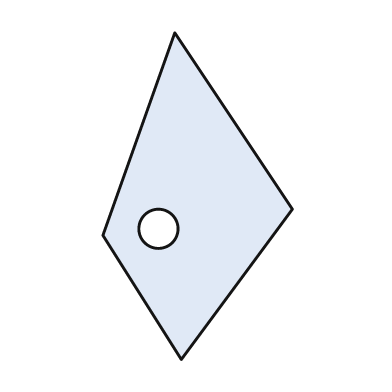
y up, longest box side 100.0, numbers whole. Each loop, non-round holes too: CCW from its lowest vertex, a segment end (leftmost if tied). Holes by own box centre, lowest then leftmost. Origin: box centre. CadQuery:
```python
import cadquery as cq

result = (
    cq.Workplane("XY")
    .moveTo(-5.0, -50.0)
    .lineTo(29.0, -4.0)
    .lineTo(-7.0, 50.0)
    .lineTo(-29.0, -12.0)
    .close()
    .moveTo(-12.0, -10.0)
    .circle(6.0)
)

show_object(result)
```